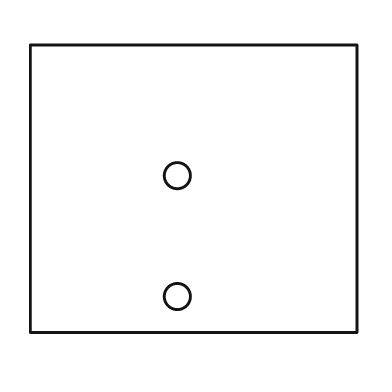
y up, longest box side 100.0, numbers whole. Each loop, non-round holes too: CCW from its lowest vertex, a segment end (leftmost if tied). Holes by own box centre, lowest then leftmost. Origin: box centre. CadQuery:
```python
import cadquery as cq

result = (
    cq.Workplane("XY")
    .moveTo(-50.0, -44.0)
    .lineTo(50.0, -44.0)
    .lineTo(50.0, 44.0)
    .lineTo(-50.0, 44.0)
    .close()
    .moveTo(-5.0, -33.0)
    .circle(4.0)
    .moveTo(-5.0, 4.0)
    .circle(4.0)
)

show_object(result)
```